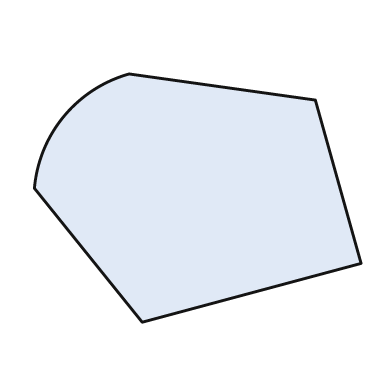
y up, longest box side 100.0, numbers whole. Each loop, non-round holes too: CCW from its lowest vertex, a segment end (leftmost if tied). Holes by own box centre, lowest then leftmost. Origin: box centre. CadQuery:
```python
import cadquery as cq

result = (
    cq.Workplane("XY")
    .moveTo(-17.0, -38.0)
    .lineTo(50.0, -20.0)
    .lineTo(36.0, 30.0)
    .lineTo(-21.0, 38.0)
    .threePointArc((-41.0, 25.0), (-50.0, 3.0))
    .close()
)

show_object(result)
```